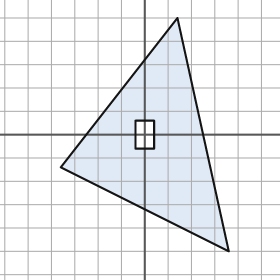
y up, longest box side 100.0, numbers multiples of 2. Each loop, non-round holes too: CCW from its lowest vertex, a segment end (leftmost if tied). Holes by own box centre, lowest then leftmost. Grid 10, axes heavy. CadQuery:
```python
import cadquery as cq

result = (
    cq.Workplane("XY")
    .moveTo(36.0, -50.0)
    .lineTo(14.0, 50.0)
    .lineTo(-36.0, -14.0)
    .close()
    .moveTo(-4.0, -6.0)
    .lineTo(4.0, -6.0)
    .lineTo(4.0, 6.0)
    .lineTo(-4.0, 6.0)
    .close()
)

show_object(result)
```